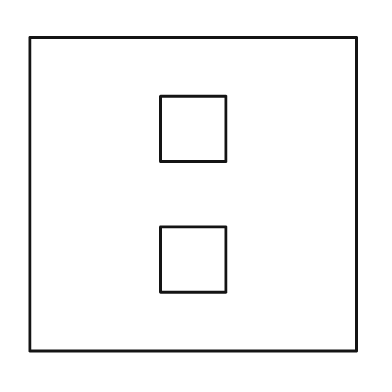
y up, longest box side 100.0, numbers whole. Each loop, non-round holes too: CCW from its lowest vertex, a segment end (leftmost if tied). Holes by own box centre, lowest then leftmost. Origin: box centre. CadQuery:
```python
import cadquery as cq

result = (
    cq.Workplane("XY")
    .moveTo(-50.0, -48.0)
    .lineTo(50.0, -48.0)
    .lineTo(50.0, 48.0)
    .lineTo(-50.0, 48.0)
    .close()
    .moveTo(-10.0, -30.0)
    .lineTo(10.0, -30.0)
    .lineTo(10.0, -10.0)
    .lineTo(-10.0, -10.0)
    .close()
    .moveTo(-10.0, 10.0)
    .lineTo(10.0, 10.0)
    .lineTo(10.0, 30.0)
    .lineTo(-10.0, 30.0)
    .close()
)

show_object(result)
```